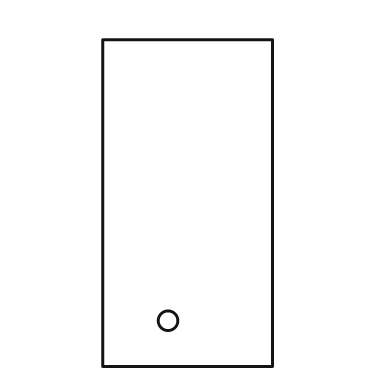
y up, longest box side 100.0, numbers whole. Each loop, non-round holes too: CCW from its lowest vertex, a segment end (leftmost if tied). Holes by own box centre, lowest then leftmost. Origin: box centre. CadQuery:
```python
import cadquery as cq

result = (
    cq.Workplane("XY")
    .moveTo(-26.0, -50.0)
    .lineTo(26.0, -50.0)
    .lineTo(26.0, 50.0)
    .lineTo(-26.0, 50.0)
    .close()
    .moveTo(-6.0, -36.0)
    .circle(3.0)
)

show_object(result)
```